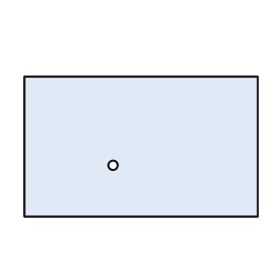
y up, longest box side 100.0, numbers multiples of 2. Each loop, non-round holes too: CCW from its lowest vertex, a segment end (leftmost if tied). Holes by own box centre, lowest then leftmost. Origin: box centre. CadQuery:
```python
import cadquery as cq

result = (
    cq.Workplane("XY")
    .moveTo(-50.0, -30.0)
    .lineTo(50.0, -30.0)
    .lineTo(50.0, 30.0)
    .lineTo(-50.0, 30.0)
    .close()
    .moveTo(-12.0, -8.0)
    .circle(2.0)
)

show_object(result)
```